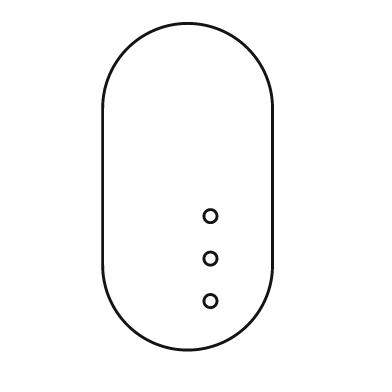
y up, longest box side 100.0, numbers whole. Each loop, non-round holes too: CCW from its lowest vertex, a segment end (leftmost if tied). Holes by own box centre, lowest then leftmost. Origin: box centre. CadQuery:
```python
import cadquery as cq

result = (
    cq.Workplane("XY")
    .moveTo(-26.0, -24.0)
    .threePointArc((0.0, -50.0), (26.0, -24.0))
    .lineTo(26.0, 24.0)
    .threePointArc((0.0, 50.0), (-26.0, 24.0))
    .close()
    .moveTo(7.0, -35.0)
    .circle(2.0)
    .moveTo(7.0, -22.0)
    .circle(2.0)
    .moveTo(7.0, -9.0)
    .circle(2.0)
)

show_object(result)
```